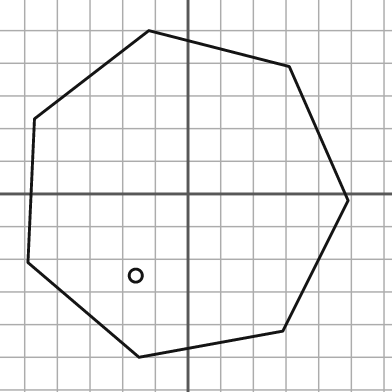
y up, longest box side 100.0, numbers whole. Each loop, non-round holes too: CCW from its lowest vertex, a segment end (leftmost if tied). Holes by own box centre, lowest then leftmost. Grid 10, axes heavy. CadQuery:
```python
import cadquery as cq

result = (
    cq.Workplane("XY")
    .moveTo(-15.0, -50.0)
    .lineTo(29.0, -42.0)
    .lineTo(49.0, -2.0)
    .lineTo(31.0, 39.0)
    .lineTo(-12.0, 50.0)
    .lineTo(-47.0, 23.0)
    .lineTo(-49.0, -21.0)
    .close()
    .moveTo(-16.0, -25.0)
    .circle(2.0)
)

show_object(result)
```